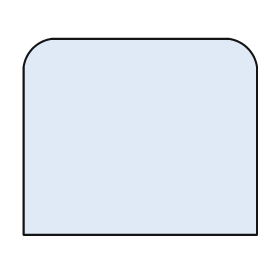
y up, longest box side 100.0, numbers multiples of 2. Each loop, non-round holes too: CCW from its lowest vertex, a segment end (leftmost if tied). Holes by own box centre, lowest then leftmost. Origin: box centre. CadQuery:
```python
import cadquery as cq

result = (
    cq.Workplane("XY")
    .moveTo(-50.0, -42.0)
    .lineTo(50.0, -42.0)
    .lineTo(50.0, 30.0)
    .threePointArc((46.0, 38.0), (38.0, 42.0))
    .lineTo(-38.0, 42.0)
    .threePointArc((-46.0, 38.0), (-50.0, 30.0))
    .close()
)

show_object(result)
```